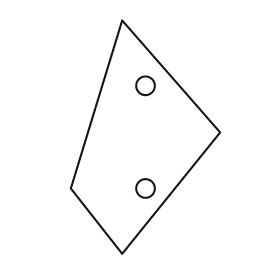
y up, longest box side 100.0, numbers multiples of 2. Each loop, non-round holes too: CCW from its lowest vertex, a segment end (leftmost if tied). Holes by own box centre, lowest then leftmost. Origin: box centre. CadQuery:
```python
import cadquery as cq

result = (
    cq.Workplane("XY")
    .moveTo(-10.0, -50.0)
    .lineTo(32.0, 2.0)
    .lineTo(-10.0, 50.0)
    .lineTo(-32.0, -22.0)
    .close()
    .moveTo(0.0, -22.0)
    .circle(4.0)
    .moveTo(0.0, 22.0)
    .circle(4.0)
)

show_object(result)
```